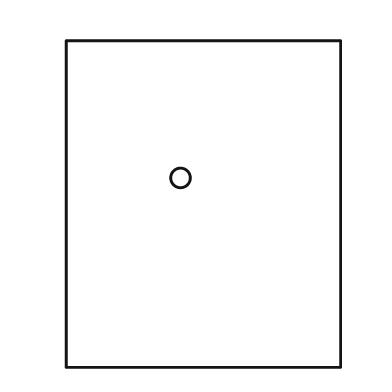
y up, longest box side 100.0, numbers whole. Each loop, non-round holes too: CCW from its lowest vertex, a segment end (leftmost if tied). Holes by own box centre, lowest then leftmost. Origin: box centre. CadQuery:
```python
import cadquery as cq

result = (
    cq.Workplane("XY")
    .moveTo(-42.0, -50.0)
    .lineTo(42.0, -50.0)
    .lineTo(42.0, 50.0)
    .lineTo(-42.0, 50.0)
    .close()
    .moveTo(-7.0, 8.0)
    .circle(3.0)
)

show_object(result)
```